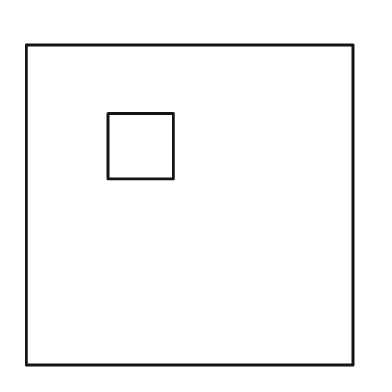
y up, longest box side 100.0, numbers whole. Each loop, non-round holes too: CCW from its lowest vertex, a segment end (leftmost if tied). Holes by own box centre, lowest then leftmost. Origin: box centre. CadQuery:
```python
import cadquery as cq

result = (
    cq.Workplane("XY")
    .moveTo(-50.0, -49.0)
    .lineTo(50.0, -49.0)
    .lineTo(50.0, 49.0)
    .lineTo(-50.0, 49.0)
    .close()
    .moveTo(-25.0, 8.0)
    .lineTo(-5.0, 8.0)
    .lineTo(-5.0, 28.0)
    .lineTo(-25.0, 28.0)
    .close()
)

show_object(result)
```